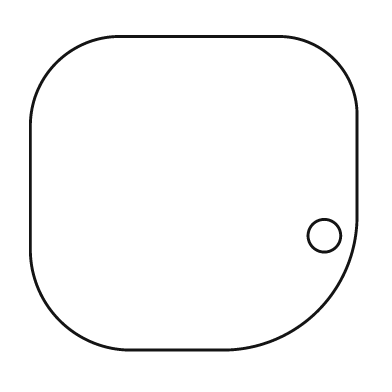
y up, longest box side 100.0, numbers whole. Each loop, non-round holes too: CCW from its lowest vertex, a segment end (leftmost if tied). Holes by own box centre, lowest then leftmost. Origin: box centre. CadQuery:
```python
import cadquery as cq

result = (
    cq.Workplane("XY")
    .moveTo(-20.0, -48.0)
    .lineTo(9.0, -48.0)
    .threePointArc((38.0, -36.0), (50.0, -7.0))
    .lineTo(50.0, 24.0)
    .threePointArc((43.0, 41.0), (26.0, 48.0))
    .lineTo(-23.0, 48.0)
    .threePointArc((-42.0, 40.0), (-50.0, 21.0))
    .lineTo(-50.0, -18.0)
    .threePointArc((-41.0, -39.0), (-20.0, -48.0))
    .close()
    .moveTo(40.0, -13.0)
    .circle(5.0)
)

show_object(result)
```